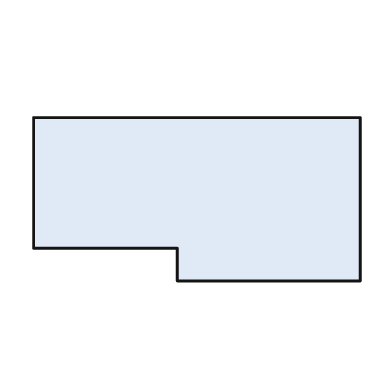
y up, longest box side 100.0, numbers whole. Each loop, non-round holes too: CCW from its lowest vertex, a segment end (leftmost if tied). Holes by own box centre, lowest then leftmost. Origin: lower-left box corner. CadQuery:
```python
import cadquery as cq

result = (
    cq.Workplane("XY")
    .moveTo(44.0, 0.0)
    .lineTo(100.0, 0.0)
    .lineTo(100.0, 50.0)
    .lineTo(0.0, 50.0)
    .lineTo(0.0, 10.0)
    .lineTo(44.0, 10.0)
    .close()
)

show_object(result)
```